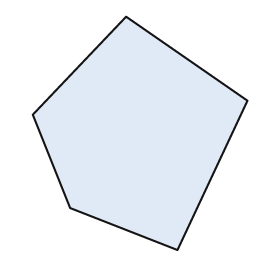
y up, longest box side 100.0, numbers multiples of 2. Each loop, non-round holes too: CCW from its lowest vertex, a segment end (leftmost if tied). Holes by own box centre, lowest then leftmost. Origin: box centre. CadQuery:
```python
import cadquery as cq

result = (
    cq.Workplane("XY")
    .moveTo(16.0, -50.0)
    .lineTo(46.0, 14.0)
    .lineTo(-6.0, 50.0)
    .lineTo(-46.0, 8.0)
    .lineTo(-30.0, -32.0)
    .close()
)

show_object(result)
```